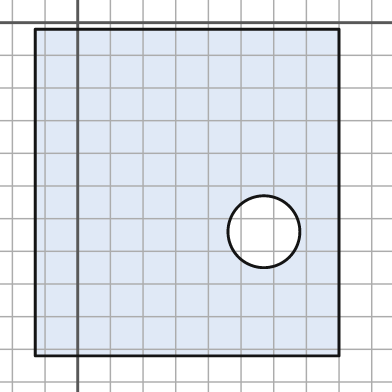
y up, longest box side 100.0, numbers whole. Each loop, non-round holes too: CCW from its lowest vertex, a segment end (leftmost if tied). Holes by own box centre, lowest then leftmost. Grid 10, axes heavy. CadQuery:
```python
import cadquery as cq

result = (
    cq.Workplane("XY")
    .moveTo(-13.0, -102.0)
    .lineTo(80.0, -102.0)
    .lineTo(80.0, -2.0)
    .lineTo(-13.0, -2.0)
    .close()
    .moveTo(57.0, -64.0)
    .circle(11.0)
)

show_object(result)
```